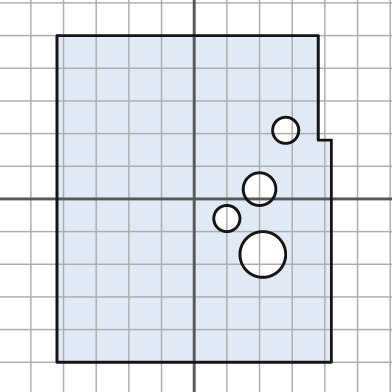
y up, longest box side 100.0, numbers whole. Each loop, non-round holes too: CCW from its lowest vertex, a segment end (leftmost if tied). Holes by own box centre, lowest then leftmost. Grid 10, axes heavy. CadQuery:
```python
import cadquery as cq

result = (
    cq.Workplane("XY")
    .moveTo(-42.0, -50.0)
    .lineTo(42.0, -50.0)
    .lineTo(42.0, 18.0)
    .lineTo(38.0, 18.0)
    .lineTo(38.0, 50.0)
    .lineTo(-42.0, 50.0)
    .close()
    .moveTo(21.0, -17.0)
    .circle(7.0)
    .moveTo(10.0, -6.0)
    .circle(4.0)
    .moveTo(20.0, 3.0)
    .circle(5.0)
    .moveTo(28.0, 21.0)
    .circle(4.0)
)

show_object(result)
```